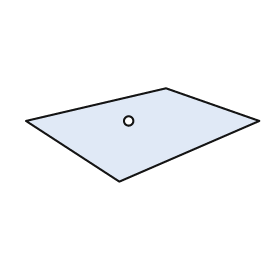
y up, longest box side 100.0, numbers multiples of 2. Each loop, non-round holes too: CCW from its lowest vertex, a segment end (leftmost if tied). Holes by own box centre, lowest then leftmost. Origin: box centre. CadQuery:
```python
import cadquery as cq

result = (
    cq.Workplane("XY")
    .moveTo(-10.0, -20.0)
    .lineTo(50.0, 6.0)
    .lineTo(10.0, 20.0)
    .lineTo(-50.0, 6.0)
    .close()
    .moveTo(-6.0, 6.0)
    .circle(2.0)
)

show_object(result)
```